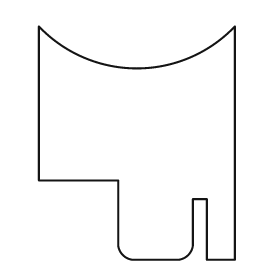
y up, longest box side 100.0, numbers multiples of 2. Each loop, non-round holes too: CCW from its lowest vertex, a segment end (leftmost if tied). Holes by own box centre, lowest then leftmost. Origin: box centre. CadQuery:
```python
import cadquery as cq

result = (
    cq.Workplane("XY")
    .moveTo(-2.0, -50.0)
    .lineTo(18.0, -50.0)
    .threePointArc((22.0, -48.0), (24.0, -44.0))
    .lineTo(24.0, -24.0)
    .lineTo(30.0, -24.0)
    .lineTo(30.0, -50.0)
    .lineTo(42.0, -50.0)
    .lineTo(42.0, 50.0)
    .threePointArc((0.0, 32.0), (-42.0, 50.0))
    .lineTo(-42.0, -16.0)
    .lineTo(-8.0, -16.0)
    .lineTo(-8.0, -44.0)
    .threePointArc((-6.0, -48.0), (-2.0, -50.0))
    .close()
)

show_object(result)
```